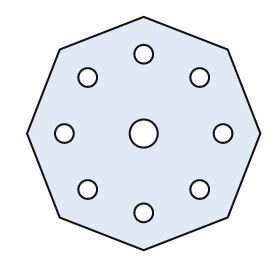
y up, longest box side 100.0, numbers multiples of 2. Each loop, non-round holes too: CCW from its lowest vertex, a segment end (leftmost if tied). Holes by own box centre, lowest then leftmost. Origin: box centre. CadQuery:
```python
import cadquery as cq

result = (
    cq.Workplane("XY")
    .moveTo(0.0, -50.0)
    .lineTo(36.0, -36.0)
    .lineTo(50.0, 0.0)
    .lineTo(36.0, 36.0)
    .lineTo(0.0, 50.0)
    .lineTo(-36.0, 36.0)
    .lineTo(-50.0, 0.0)
    .lineTo(-36.0, -36.0)
    .close()
    .moveTo(0.0, -34.0)
    .circle(4.0)
    .moveTo(-24.0, -24.0)
    .circle(4.0)
    .moveTo(24.0, -24.0)
    .circle(4.0)
    .moveTo(-34.0, 0.0)
    .circle(4.0)
    .moveTo(0.0, 0.0)
    .circle(6.0)
    .moveTo(34.0, 0.0)
    .circle(4.0)
    .moveTo(-24.0, 24.0)
    .circle(4.0)
    .moveTo(24.0, 24.0)
    .circle(4.0)
    .moveTo(0.0, 34.0)
    .circle(4.0)
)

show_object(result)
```